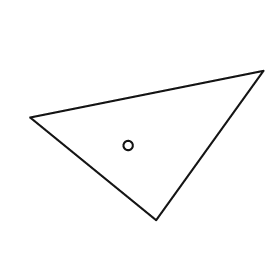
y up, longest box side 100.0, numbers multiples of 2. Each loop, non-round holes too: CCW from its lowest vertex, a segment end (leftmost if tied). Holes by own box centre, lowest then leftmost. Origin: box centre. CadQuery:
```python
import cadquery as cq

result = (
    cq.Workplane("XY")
    .moveTo(4.0, -32.0)
    .lineTo(50.0, 32.0)
    .lineTo(-50.0, 12.0)
    .close()
    .moveTo(-8.0, 0.0)
    .circle(2.0)
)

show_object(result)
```